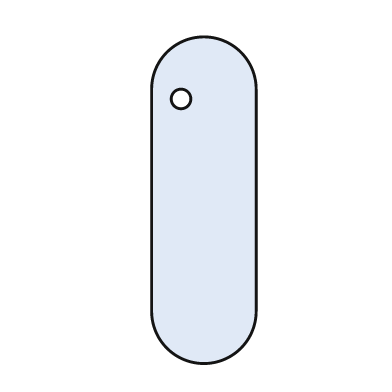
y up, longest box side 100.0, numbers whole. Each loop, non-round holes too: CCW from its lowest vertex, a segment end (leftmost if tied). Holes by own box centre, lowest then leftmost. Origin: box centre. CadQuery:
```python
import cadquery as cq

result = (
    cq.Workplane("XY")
    .moveTo(-16.0, -34.0)
    .threePointArc((0.0, -50.0), (16.0, -34.0))
    .lineTo(16.0, 34.0)
    .threePointArc((0.0, 50.0), (-16.0, 34.0))
    .close()
    .moveTo(-7.0, 31.0)
    .circle(3.0)
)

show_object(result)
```